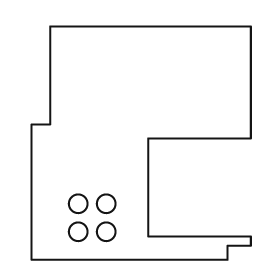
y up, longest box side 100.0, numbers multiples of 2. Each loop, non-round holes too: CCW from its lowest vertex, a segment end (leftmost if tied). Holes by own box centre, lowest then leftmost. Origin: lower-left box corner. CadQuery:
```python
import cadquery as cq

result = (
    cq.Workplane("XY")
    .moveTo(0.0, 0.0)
    .lineTo(84.0, 0.0)
    .lineTo(84.0, 6.0)
    .lineTo(94.0, 6.0)
    .lineTo(94.0, 10.0)
    .lineTo(50.0, 10.0)
    .lineTo(50.0, 52.0)
    .lineTo(94.0, 52.0)
    .lineTo(94.0, 100.0)
    .lineTo(8.0, 100.0)
    .lineTo(8.0, 58.0)
    .lineTo(0.0, 58.0)
    .close()
    .moveTo(20.0, 12.0)
    .circle(4.0)
    .moveTo(32.0, 12.0)
    .circle(4.0)
    .moveTo(20.0, 24.0)
    .circle(4.0)
    .moveTo(32.0, 24.0)
    .circle(4.0)
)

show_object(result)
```